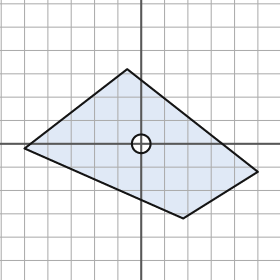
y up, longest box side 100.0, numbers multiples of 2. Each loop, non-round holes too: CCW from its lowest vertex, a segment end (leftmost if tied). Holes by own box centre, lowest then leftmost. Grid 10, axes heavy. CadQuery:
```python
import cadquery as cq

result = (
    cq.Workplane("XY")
    .moveTo(18.0, -32.0)
    .lineTo(50.0, -12.0)
    .lineTo(-6.0, 32.0)
    .lineTo(-50.0, -2.0)
    .close()
    .moveTo(0.0, 0.0)
    .circle(4.0)
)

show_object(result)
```